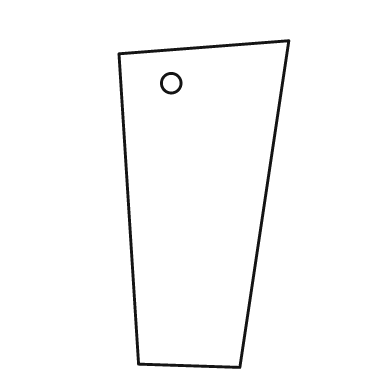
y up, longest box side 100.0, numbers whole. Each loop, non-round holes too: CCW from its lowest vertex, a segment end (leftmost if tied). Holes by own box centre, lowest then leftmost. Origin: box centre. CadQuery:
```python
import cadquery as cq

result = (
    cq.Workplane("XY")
    .moveTo(11.0, -50.0)
    .lineTo(26.0, 50.0)
    .lineTo(-26.0, 46.0)
    .lineTo(-20.0, -49.0)
    .close()
    .moveTo(-10.0, 37.0)
    .circle(3.0)
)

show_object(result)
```